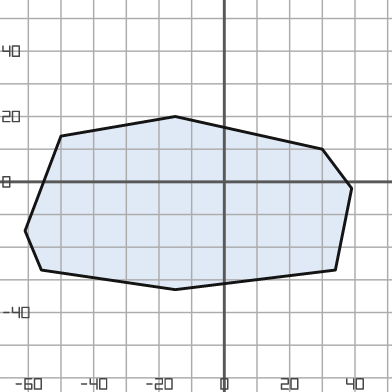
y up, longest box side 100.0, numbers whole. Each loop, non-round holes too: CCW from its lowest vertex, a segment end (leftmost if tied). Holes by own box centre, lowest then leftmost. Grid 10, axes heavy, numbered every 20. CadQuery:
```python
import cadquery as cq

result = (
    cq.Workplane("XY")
    .moveTo(-15.0, -33.0)
    .lineTo(34.0, -27.0)
    .lineTo(39.0, -2.0)
    .lineTo(30.0, 10.0)
    .lineTo(-15.0, 20.0)
    .lineTo(-50.0, 14.0)
    .lineTo(-61.0, -15.0)
    .lineTo(-56.0, -27.0)
    .close()
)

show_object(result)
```